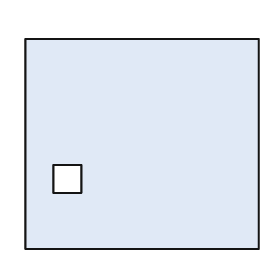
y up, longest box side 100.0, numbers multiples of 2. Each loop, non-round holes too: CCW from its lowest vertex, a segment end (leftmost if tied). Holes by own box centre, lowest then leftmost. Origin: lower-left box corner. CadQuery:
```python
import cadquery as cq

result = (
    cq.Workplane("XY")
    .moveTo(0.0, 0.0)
    .lineTo(100.0, 0.0)
    .lineTo(100.0, 90.0)
    .lineTo(0.0, 90.0)
    .close()
    .moveTo(12.0, 24.0)
    .lineTo(24.0, 24.0)
    .lineTo(24.0, 36.0)
    .lineTo(12.0, 36.0)
    .close()
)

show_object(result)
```